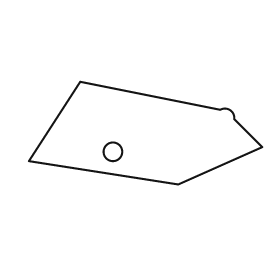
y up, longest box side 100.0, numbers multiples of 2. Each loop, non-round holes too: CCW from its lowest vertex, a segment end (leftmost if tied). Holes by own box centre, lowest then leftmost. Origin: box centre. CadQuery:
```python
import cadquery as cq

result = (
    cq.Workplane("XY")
    .moveTo(14.0, -22.0)
    .lineTo(50.0, -6.0)
    .lineTo(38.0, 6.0)
    .threePointArc((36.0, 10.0), (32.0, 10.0))
    .lineTo(-28.0, 22.0)
    .lineTo(-50.0, -12.0)
    .close()
    .moveTo(-14.0, -8.0)
    .circle(4.0)
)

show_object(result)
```